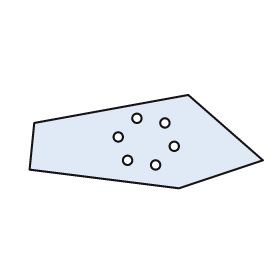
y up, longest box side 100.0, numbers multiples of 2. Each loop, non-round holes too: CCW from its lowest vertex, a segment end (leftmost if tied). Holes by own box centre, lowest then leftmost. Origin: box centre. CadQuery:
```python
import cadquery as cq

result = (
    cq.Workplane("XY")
    .moveTo(14.0, -20.0)
    .lineTo(50.0, -8.0)
    .lineTo(18.0, 20.0)
    .lineTo(-48.0, 8.0)
    .lineTo(-50.0, -12.0)
    .close()
    .moveTo(4.0, -10.0)
    .circle(2.0)
    .moveTo(-8.0, -8.0)
    .circle(2.0)
    .moveTo(12.0, -2.0)
    .circle(2.0)
    .moveTo(-12.0, 2.0)
    .circle(2.0)
    .moveTo(8.0, 8.0)
    .circle(2.0)
    .moveTo(-4.0, 10.0)
    .circle(2.0)
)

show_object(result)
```